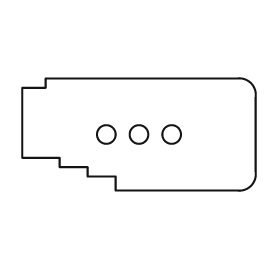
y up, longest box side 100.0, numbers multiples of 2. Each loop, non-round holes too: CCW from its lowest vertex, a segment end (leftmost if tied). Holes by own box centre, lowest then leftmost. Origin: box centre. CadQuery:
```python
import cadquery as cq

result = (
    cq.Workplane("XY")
    .moveTo(-10.0, -24.0)
    .lineTo(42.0, -24.0)
    .threePointArc((48.0, -22.0), (50.0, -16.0))
    .lineTo(50.0, 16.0)
    .threePointArc((48.0, 22.0), (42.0, 24.0))
    .lineTo(-40.0, 24.0)
    .lineTo(-40.0, 20.0)
    .lineTo(-50.0, 20.0)
    .lineTo(-50.0, -10.0)
    .lineTo(-34.0, -10.0)
    .lineTo(-34.0, -14.0)
    .lineTo(-22.0, -14.0)
    .lineTo(-22.0, -18.0)
    .lineTo(-10.0, -18.0)
    .close()
    .moveTo(-14.0, 0.0)
    .circle(4.0)
    .moveTo(0.0, 0.0)
    .circle(4.0)
    .moveTo(14.0, 0.0)
    .circle(4.0)
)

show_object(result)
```